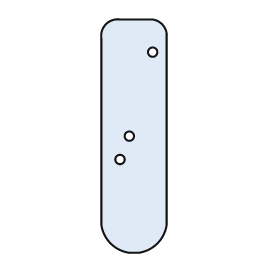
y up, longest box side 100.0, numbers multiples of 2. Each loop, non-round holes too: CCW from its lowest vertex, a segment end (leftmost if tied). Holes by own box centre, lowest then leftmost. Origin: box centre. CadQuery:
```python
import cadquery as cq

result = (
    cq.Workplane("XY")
    .moveTo(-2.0, -50.0)
    .lineTo(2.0, -50.0)
    .threePointArc((10.0, -46.0), (14.0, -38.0))
    .lineTo(14.0, 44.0)
    .threePointArc((12.0, 48.0), (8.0, 50.0))
    .lineTo(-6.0, 50.0)
    .threePointArc((-12.0, 48.0), (-14.0, 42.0))
    .lineTo(-14.0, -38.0)
    .threePointArc((-10.0, -46.0), (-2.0, -50.0))
    .close()
    .moveTo(-6.0, -10.0)
    .circle(2.0)
    .moveTo(-2.0, 0.0)
    .circle(2.0)
    .moveTo(8.0, 36.0)
    .circle(2.0)
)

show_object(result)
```